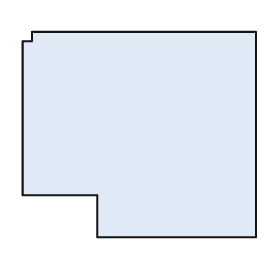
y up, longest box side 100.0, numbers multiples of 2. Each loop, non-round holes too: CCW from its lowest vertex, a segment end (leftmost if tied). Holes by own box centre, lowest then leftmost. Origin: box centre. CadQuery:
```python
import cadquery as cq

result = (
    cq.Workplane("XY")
    .moveTo(-18.0, -44.0)
    .lineTo(50.0, -44.0)
    .lineTo(50.0, 44.0)
    .lineTo(-46.0, 44.0)
    .lineTo(-46.0, 40.0)
    .lineTo(-50.0, 40.0)
    .lineTo(-50.0, -26.0)
    .lineTo(-18.0, -26.0)
    .close()
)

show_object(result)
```